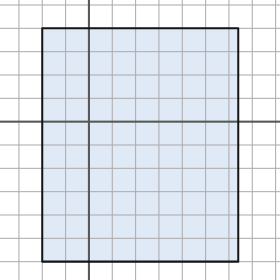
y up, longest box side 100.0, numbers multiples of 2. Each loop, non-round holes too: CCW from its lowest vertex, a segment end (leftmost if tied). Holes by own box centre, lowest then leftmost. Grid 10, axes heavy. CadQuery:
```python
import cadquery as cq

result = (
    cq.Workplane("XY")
    .moveTo(-20.0, -60.0)
    .lineTo(64.0, -60.0)
    .lineTo(64.0, 40.0)
    .lineTo(-20.0, 40.0)
    .close()
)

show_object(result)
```